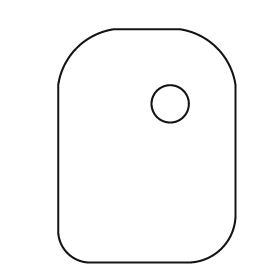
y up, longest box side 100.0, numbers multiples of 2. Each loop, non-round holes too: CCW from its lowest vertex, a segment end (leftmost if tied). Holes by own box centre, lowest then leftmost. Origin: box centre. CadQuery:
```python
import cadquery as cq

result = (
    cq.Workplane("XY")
    .moveTo(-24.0, -50.0)
    .lineTo(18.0, -50.0)
    .threePointArc((32.0, -44.0), (38.0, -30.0))
    .lineTo(38.0, 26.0)
    .threePointArc((30.0, 42.0), (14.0, 50.0))
    .lineTo(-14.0, 50.0)
    .threePointArc((-30.0, 42.0), (-38.0, 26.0))
    .lineTo(-38.0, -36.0)
    .threePointArc((-34.0, -46.0), (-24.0, -50.0))
    .close()
    .moveTo(10.0, 18.0)
    .circle(8.0)
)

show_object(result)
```